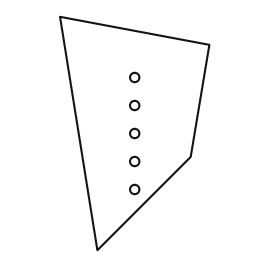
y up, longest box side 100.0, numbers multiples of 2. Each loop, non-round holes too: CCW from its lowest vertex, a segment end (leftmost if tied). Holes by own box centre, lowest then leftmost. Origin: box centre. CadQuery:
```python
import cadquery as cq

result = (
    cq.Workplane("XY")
    .moveTo(-16.0, -50.0)
    .lineTo(24.0, -10.0)
    .lineTo(32.0, 38.0)
    .lineTo(-32.0, 50.0)
    .close()
    .moveTo(0.0, -24.0)
    .circle(2.0)
    .moveTo(0.0, -12.0)
    .circle(2.0)
    .moveTo(0.0, 0.0)
    .circle(2.0)
    .moveTo(0.0, 12.0)
    .circle(2.0)
    .moveTo(0.0, 24.0)
    .circle(2.0)
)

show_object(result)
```